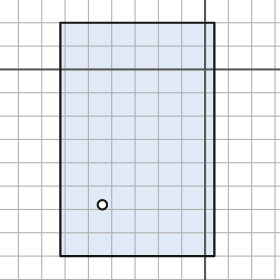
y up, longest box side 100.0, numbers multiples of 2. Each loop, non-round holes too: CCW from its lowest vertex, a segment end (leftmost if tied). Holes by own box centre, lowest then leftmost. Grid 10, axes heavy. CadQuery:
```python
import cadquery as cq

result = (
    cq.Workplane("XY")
    .moveTo(-62.0, -80.0)
    .lineTo(4.0, -80.0)
    .lineTo(4.0, 20.0)
    .lineTo(-62.0, 20.0)
    .close()
    .moveTo(-44.0, -58.0)
    .circle(2.0)
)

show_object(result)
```